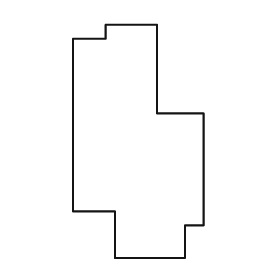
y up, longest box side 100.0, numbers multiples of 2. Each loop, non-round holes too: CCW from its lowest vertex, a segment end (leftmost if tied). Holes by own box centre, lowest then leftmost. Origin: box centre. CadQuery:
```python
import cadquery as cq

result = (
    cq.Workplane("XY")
    .moveTo(-10.0, -50.0)
    .lineTo(20.0, -50.0)
    .lineTo(20.0, -36.0)
    .lineTo(28.0, -36.0)
    .lineTo(28.0, 12.0)
    .lineTo(8.0, 12.0)
    .lineTo(8.0, 50.0)
    .lineTo(-14.0, 50.0)
    .lineTo(-14.0, 44.0)
    .lineTo(-28.0, 44.0)
    .lineTo(-28.0, -30.0)
    .lineTo(-10.0, -30.0)
    .close()
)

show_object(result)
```